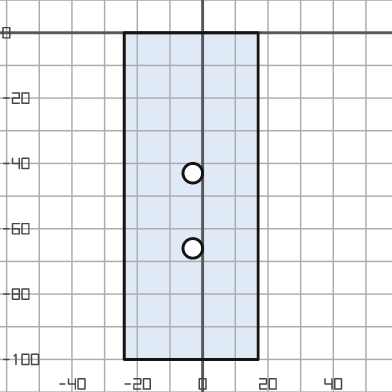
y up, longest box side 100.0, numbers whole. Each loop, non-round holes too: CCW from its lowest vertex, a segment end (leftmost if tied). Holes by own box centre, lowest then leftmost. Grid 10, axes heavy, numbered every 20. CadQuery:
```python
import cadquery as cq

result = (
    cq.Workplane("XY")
    .moveTo(-24.0, -100.0)
    .lineTo(17.0, -100.0)
    .lineTo(17.0, 0.0)
    .lineTo(-24.0, 0.0)
    .close()
    .moveTo(-3.0, -66.0)
    .circle(3.0)
    .moveTo(-3.0, -43.0)
    .circle(3.0)
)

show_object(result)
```